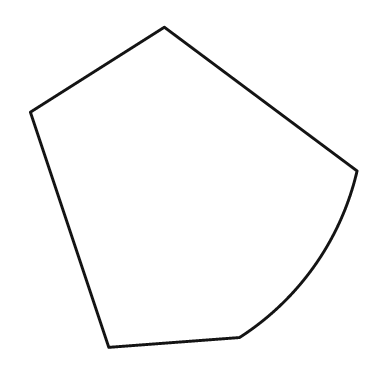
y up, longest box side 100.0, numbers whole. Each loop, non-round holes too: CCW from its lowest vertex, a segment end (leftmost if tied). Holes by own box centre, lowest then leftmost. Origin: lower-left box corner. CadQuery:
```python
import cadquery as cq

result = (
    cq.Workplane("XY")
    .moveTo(24.0, 0.0)
    .lineTo(64.0, 3.0)
    .threePointArc((87.0, 25.0), (100.0, 54.0))
    .lineTo(41.0, 98.0)
    .lineTo(0.0, 72.0)
    .close()
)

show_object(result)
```